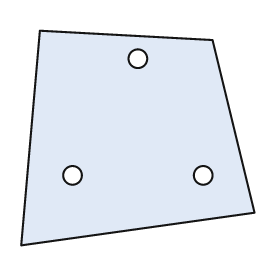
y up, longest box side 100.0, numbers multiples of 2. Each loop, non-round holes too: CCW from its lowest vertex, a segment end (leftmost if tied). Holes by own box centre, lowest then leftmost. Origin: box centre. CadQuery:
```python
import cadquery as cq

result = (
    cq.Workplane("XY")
    .moveTo(-50.0, -46.0)
    .lineTo(50.0, -32.0)
    .lineTo(32.0, 42.0)
    .lineTo(-42.0, 46.0)
    .close()
    .moveTo(-28.0, -16.0)
    .circle(4.0)
    .moveTo(28.0, -16.0)
    .circle(4.0)
    .moveTo(0.0, 34.0)
    .circle(4.0)
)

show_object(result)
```